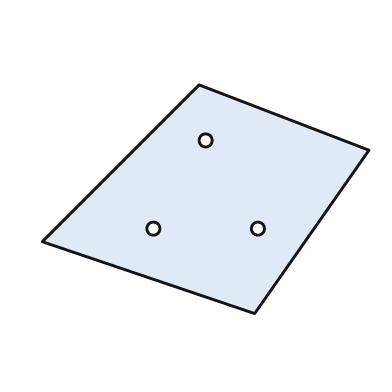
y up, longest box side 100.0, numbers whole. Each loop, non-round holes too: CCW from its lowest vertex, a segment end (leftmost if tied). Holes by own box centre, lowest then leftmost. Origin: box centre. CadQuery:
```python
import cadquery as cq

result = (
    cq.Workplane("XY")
    .moveTo(15.0, -35.0)
    .lineTo(50.0, 15.0)
    .lineTo(-2.0, 35.0)
    .lineTo(-50.0, -13.0)
    .close()
    .moveTo(-16.0, -9.0)
    .circle(2.0)
    .moveTo(16.0, -9.0)
    .circle(2.0)
    .moveTo(0.0, 18.0)
    .circle(2.0)
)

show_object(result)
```